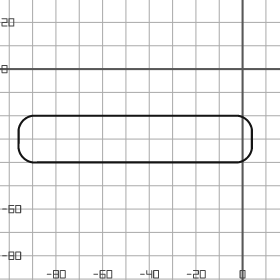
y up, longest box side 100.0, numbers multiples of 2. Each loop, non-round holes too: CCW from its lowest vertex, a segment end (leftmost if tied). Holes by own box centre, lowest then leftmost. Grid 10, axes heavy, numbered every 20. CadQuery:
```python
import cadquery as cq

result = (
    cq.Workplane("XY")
    .moveTo(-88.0, -40.0)
    .lineTo(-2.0, -40.0)
    .threePointArc((2.0, -38.0), (4.0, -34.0))
    .lineTo(4.0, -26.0)
    .threePointArc((2.0, -22.0), (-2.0, -20.0))
    .lineTo(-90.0, -20.0)
    .threePointArc((-94.0, -22.0), (-96.0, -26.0))
    .lineTo(-96.0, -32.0)
    .threePointArc((-94.0, -38.0), (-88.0, -40.0))
    .close()
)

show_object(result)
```